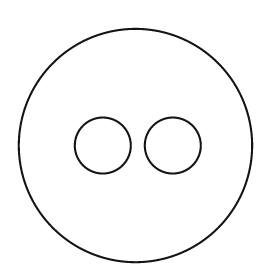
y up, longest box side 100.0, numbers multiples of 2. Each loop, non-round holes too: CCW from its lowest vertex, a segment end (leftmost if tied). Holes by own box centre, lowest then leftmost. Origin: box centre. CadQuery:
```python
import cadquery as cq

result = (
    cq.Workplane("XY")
    .moveTo(0.0, 0.0)
    .circle(50.0)
    .moveTo(-14.0, 0.0)
    .circle(12.0)
    .moveTo(16.0, 0.0)
    .circle(12.0)
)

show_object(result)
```